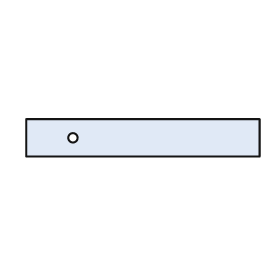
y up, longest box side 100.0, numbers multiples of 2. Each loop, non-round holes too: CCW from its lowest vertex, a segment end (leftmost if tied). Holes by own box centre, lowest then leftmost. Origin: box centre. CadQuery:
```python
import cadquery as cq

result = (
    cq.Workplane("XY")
    .moveTo(-50.0, -8.0)
    .lineTo(50.0, -8.0)
    .lineTo(50.0, 8.0)
    .lineTo(-50.0, 8.0)
    .close()
    .moveTo(-30.0, 0.0)
    .circle(2.0)
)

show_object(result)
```